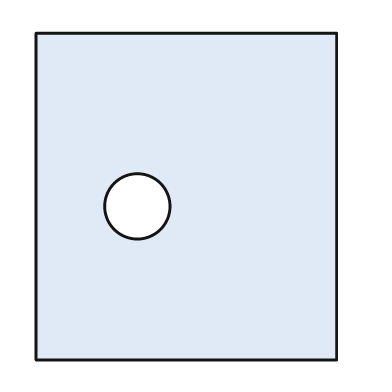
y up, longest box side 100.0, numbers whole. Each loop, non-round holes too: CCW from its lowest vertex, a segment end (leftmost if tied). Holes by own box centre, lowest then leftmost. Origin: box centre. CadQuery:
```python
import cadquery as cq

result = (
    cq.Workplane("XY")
    .moveTo(-46.0, -50.0)
    .lineTo(46.0, -50.0)
    .lineTo(46.0, 50.0)
    .lineTo(-46.0, 50.0)
    .close()
    .moveTo(-15.0, -3.0)
    .circle(10.0)
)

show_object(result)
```